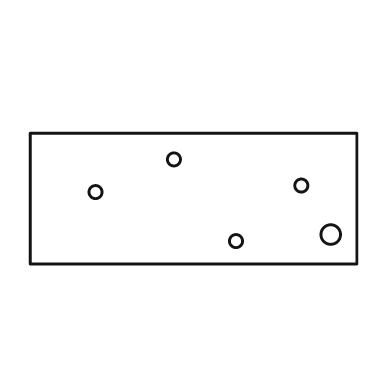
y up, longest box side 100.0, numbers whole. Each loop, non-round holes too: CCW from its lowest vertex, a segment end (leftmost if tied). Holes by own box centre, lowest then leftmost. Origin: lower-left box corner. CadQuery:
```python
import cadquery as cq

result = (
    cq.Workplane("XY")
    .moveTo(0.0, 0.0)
    .lineTo(100.0, 0.0)
    .lineTo(100.0, 40.0)
    .lineTo(0.0, 40.0)
    .close()
    .moveTo(63.0, 7.0)
    .circle(2.0)
    .moveTo(92.0, 9.0)
    .circle(3.0)
    .moveTo(20.0, 22.0)
    .circle(2.0)
    .moveTo(83.0, 24.0)
    .circle(2.0)
    .moveTo(44.0, 32.0)
    .circle(2.0)
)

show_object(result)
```